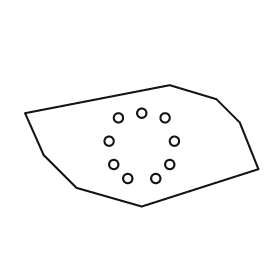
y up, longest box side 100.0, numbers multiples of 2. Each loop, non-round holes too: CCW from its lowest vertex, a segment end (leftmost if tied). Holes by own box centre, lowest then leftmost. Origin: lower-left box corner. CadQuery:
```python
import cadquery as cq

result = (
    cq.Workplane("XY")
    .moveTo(50.0, 0.0)
    .lineTo(100.0, 16.0)
    .lineTo(92.0, 36.0)
    .lineTo(82.0, 46.0)
    .lineTo(62.0, 52.0)
    .lineTo(0.0, 40.0)
    .lineTo(8.0, 22.0)
    .lineTo(22.0, 8.0)
    .close()
    .moveTo(44.0, 12.0)
    .circle(2.0)
    .moveTo(56.0, 12.0)
    .circle(2.0)
    .moveTo(38.0, 18.0)
    .circle(2.0)
    .moveTo(62.0, 18.0)
    .circle(2.0)
    .moveTo(36.0, 28.0)
    .circle(2.0)
    .moveTo(64.0, 28.0)
    .circle(2.0)
    .moveTo(40.0, 38.0)
    .circle(2.0)
    .moveTo(60.0, 38.0)
    .circle(2.0)
    .moveTo(50.0, 40.0)
    .circle(2.0)
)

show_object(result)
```